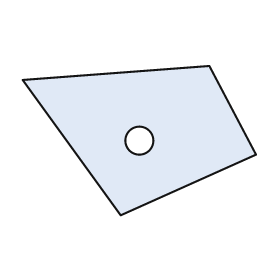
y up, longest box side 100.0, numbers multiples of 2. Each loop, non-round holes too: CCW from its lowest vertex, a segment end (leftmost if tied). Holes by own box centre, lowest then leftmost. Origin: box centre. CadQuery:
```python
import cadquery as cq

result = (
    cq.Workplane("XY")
    .moveTo(-8.0, -32.0)
    .lineTo(50.0, -6.0)
    .lineTo(30.0, 32.0)
    .lineTo(-50.0, 26.0)
    .close()
    .moveTo(0.0, 0.0)
    .circle(6.0)
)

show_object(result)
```